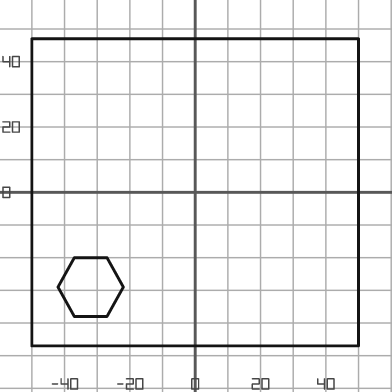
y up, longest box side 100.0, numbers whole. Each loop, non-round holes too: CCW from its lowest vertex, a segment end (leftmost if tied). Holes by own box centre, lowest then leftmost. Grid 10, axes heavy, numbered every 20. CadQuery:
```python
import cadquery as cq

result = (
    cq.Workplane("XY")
    .moveTo(-50.0, -47.0)
    .lineTo(50.0, -47.0)
    .lineTo(50.0, 47.0)
    .lineTo(-50.0, 47.0)
    .close()
    .moveTo(-37.0, -38.0)
    .lineTo(-27.0, -38.0)
    .lineTo(-22.0, -29.0)
    .lineTo(-27.0, -20.0)
    .lineTo(-37.0, -20.0)
    .lineTo(-42.0, -29.0)
    .close()
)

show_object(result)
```